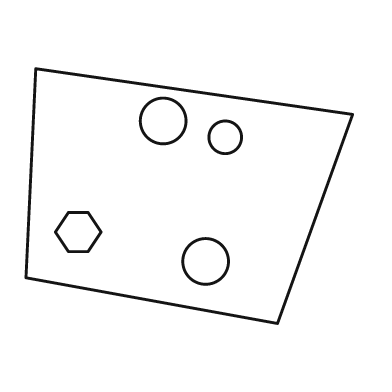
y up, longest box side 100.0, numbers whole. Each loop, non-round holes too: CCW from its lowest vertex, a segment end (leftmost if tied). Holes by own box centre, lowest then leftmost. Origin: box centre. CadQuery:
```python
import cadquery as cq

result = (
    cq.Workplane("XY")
    .moveTo(27.0, -39.0)
    .lineTo(50.0, 25.0)
    .lineTo(-47.0, 39.0)
    .lineTo(-50.0, -25.0)
    .close()
    .moveTo(5.0, -20.0)
    .circle(7.0)
    .moveTo(-37.0, -17.0)
    .lineTo(-31.0, -17.0)
    .lineTo(-27.0, -11.0)
    .lineTo(-31.0, -5.0)
    .lineTo(-37.0, -5.0)
    .lineTo(-41.0, -11.0)
    .close()
    .moveTo(11.0, 18.0)
    .circle(5.0)
    .moveTo(-8.0, 23.0)
    .circle(7.0)
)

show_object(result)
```